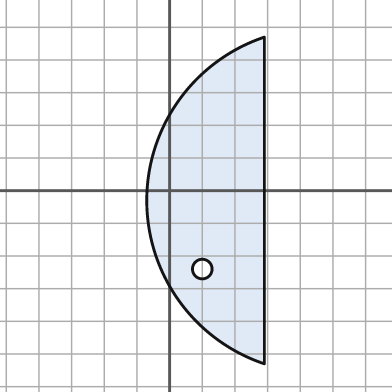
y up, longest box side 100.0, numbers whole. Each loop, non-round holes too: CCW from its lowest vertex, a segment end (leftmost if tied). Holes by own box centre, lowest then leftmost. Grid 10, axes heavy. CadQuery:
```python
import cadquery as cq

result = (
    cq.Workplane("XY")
    .moveTo(29.0, -53.0)
    .lineTo(29.0, 47.0)
    .threePointArc((-7.0, -3.0), (29.0, -53.0))
    .close()
    .moveTo(10.0, -24.0)
    .circle(3.0)
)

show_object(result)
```